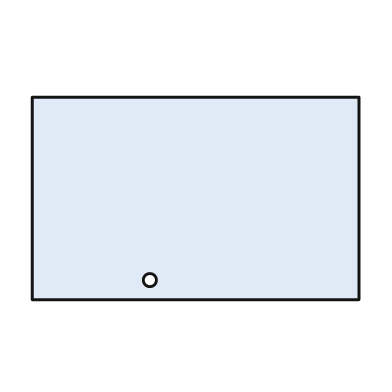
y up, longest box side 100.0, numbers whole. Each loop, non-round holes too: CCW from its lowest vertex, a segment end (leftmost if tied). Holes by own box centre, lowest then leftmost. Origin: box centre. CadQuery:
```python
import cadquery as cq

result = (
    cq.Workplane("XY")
    .moveTo(-50.0, -31.0)
    .lineTo(50.0, -31.0)
    .lineTo(50.0, 31.0)
    .lineTo(-50.0, 31.0)
    .close()
    .moveTo(-14.0, -25.0)
    .circle(2.0)
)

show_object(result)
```